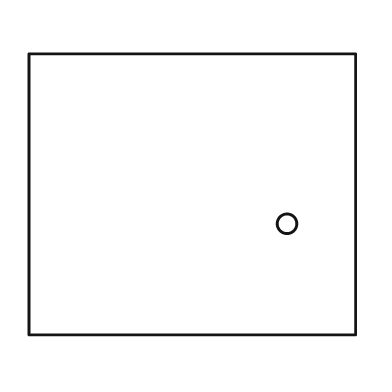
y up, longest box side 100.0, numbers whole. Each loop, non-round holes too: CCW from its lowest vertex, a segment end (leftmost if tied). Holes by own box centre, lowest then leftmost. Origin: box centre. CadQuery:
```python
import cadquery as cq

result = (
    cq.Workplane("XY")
    .moveTo(-50.0, -43.0)
    .lineTo(50.0, -43.0)
    .lineTo(50.0, 43.0)
    .lineTo(-50.0, 43.0)
    .close()
    .moveTo(29.0, -9.0)
    .circle(3.0)
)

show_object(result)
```